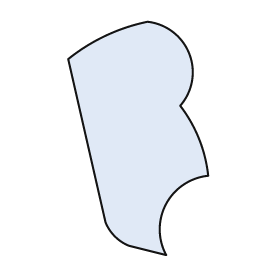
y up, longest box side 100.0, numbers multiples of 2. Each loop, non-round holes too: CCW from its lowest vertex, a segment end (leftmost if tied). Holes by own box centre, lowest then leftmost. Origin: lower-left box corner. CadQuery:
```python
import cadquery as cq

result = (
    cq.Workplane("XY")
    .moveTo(42.0, 0.0)
    .threePointArc((42.0, 22.0), (60.0, 34.0))
    .threePointArc((56.0, 50.0), (48.0, 64.0))
    .threePointArc((52.0, 86.0), (34.0, 100.0))
    .threePointArc((16.0, 94.0), (0.0, 84.0))
    .lineTo(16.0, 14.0)
    .threePointArc((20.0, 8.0), (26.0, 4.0))
    .close()
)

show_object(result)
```